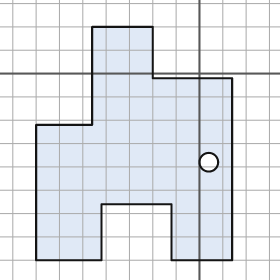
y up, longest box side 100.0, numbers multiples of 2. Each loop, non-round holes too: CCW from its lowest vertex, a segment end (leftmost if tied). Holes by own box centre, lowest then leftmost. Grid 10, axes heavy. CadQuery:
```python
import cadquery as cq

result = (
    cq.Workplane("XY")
    .moveTo(-70.0, -80.0)
    .lineTo(-42.0, -80.0)
    .lineTo(-42.0, -56.0)
    .lineTo(-12.0, -56.0)
    .lineTo(-12.0, -80.0)
    .lineTo(14.0, -80.0)
    .lineTo(14.0, -2.0)
    .lineTo(-20.0, -2.0)
    .lineTo(-20.0, 20.0)
    .lineTo(-46.0, 20.0)
    .lineTo(-46.0, -22.0)
    .lineTo(-70.0, -22.0)
    .close()
    .moveTo(4.0, -38.0)
    .circle(4.0)
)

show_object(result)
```